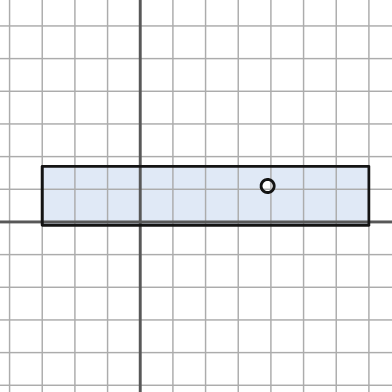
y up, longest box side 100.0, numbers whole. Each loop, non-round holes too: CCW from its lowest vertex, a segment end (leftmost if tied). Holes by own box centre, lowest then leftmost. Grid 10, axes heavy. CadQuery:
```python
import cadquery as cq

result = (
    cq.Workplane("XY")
    .moveTo(-30.0, -1.0)
    .lineTo(70.0, -1.0)
    .lineTo(70.0, 17.0)
    .lineTo(-30.0, 17.0)
    .close()
    .moveTo(39.0, 11.0)
    .circle(2.0)
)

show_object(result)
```